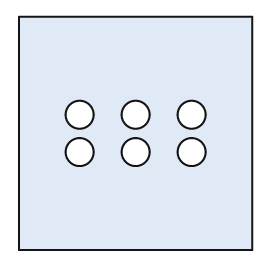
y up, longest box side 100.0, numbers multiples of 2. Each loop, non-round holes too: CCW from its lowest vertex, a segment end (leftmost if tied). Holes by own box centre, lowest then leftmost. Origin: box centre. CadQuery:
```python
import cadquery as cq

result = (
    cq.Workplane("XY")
    .moveTo(-50.0, -50.0)
    .lineTo(50.0, -50.0)
    .lineTo(50.0, 50.0)
    .lineTo(-50.0, 50.0)
    .close()
    .moveTo(-24.0, -8.0)
    .circle(6.0)
    .moveTo(0.0, -8.0)
    .circle(6.0)
    .moveTo(24.0, -8.0)
    .circle(6.0)
    .moveTo(-24.0, 8.0)
    .circle(6.0)
    .moveTo(0.0, 8.0)
    .circle(6.0)
    .moveTo(24.0, 8.0)
    .circle(6.0)
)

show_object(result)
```